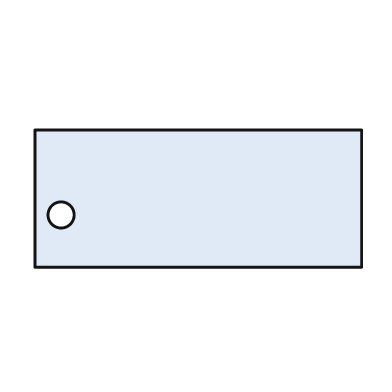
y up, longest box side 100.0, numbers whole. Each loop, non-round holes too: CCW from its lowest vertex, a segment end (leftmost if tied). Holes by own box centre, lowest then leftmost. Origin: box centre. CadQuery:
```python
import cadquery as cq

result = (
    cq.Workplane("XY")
    .moveTo(-50.0, -21.0)
    .lineTo(50.0, -21.0)
    .lineTo(50.0, 21.0)
    .lineTo(-50.0, 21.0)
    .close()
    .moveTo(-42.0, -5.0)
    .circle(4.0)
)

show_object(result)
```